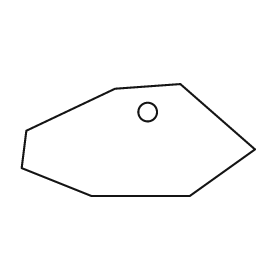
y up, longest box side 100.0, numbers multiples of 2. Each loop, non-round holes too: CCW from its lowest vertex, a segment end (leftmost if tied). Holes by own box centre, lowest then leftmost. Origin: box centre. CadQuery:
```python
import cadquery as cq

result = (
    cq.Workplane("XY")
    .moveTo(-20.0, -24.0)
    .lineTo(22.0, -24.0)
    .lineTo(50.0, -4.0)
    .lineTo(18.0, 24.0)
    .lineTo(-10.0, 22.0)
    .lineTo(-48.0, 4.0)
    .lineTo(-50.0, -12.0)
    .close()
    .moveTo(4.0, 12.0)
    .circle(4.0)
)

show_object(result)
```